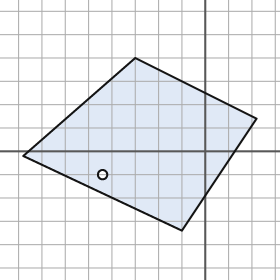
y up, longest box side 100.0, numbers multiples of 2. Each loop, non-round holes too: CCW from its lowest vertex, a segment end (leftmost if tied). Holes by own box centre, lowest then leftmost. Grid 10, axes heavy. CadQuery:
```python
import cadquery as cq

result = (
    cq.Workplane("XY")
    .moveTo(-10.0, -34.0)
    .lineTo(22.0, 14.0)
    .lineTo(-30.0, 40.0)
    .lineTo(-78.0, -2.0)
    .close()
    .moveTo(-44.0, -10.0)
    .circle(2.0)
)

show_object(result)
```